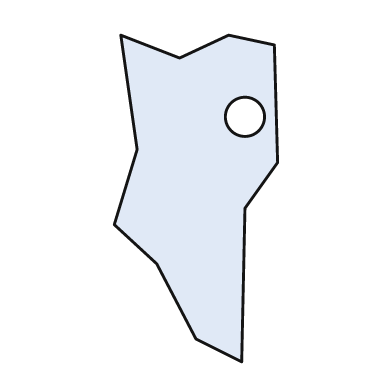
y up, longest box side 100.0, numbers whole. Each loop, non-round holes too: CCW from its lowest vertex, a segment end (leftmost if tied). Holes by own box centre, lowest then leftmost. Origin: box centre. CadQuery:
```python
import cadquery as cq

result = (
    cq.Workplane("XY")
    .moveTo(14.0, -50.0)
    .lineTo(15.0, -3.0)
    .lineTo(25.0, 11.0)
    .lineTo(24.0, 47.0)
    .lineTo(10.0, 50.0)
    .lineTo(-5.0, 43.0)
    .lineTo(-23.0, 50.0)
    .lineTo(-18.0, 15.0)
    .lineTo(-25.0, -8.0)
    .lineTo(-12.0, -20.0)
    .lineTo(0.0, -43.0)
    .close()
    .moveTo(15.0, 25.0)
    .circle(6.0)
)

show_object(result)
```